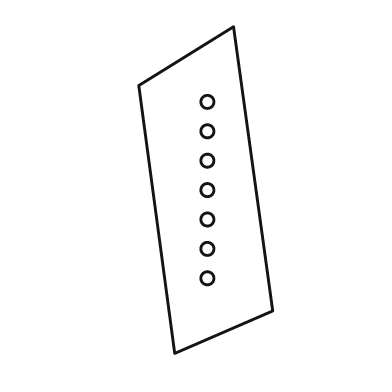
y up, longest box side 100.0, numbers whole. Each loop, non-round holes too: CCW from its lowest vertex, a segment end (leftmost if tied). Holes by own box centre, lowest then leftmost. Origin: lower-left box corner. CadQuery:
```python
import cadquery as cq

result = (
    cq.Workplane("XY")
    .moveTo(11.0, 0.0)
    .lineTo(41.0, 13.0)
    .lineTo(29.0, 100.0)
    .lineTo(0.0, 82.0)
    .close()
    .moveTo(21.0, 23.0)
    .circle(2.0)
    .moveTo(21.0, 32.0)
    .circle(2.0)
    .moveTo(21.0, 41.0)
    .circle(2.0)
    .moveTo(21.0, 50.0)
    .circle(2.0)
    .moveTo(21.0, 59.0)
    .circle(2.0)
    .moveTo(21.0, 68.0)
    .circle(2.0)
    .moveTo(21.0, 77.0)
    .circle(2.0)
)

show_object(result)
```